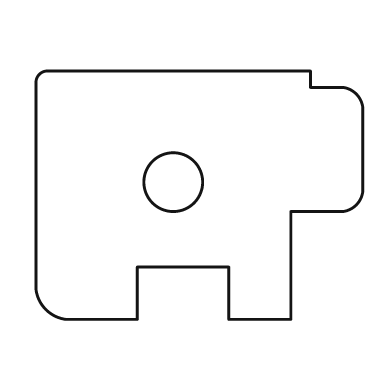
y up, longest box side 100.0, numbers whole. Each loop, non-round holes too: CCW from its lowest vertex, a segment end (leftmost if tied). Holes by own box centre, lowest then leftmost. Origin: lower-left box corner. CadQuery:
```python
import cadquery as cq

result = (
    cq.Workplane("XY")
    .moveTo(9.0, 0.0)
    .lineTo(31.0, 0.0)
    .lineTo(31.0, 16.0)
    .lineTo(59.0, 16.0)
    .lineTo(59.0, 0.0)
    .lineTo(78.0, 0.0)
    .lineTo(78.0, 33.0)
    .lineTo(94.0, 33.0)
    .threePointArc((98.0, 35.0), (100.0, 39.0))
    .lineTo(100.0, 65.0)
    .threePointArc((98.0, 69.0), (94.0, 71.0))
    .lineTo(84.0, 71.0)
    .lineTo(84.0, 76.0)
    .lineTo(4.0, 76.0)
    .threePointArc((1.0, 75.0), (0.0, 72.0))
    .lineTo(0.0, 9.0)
    .threePointArc((3.0, 3.0), (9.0, 0.0))
    .close()
    .moveTo(42.0, 42.0)
    .circle(9.0)
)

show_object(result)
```